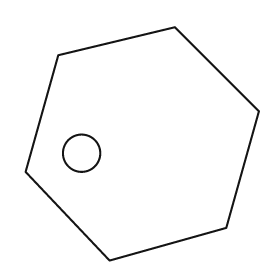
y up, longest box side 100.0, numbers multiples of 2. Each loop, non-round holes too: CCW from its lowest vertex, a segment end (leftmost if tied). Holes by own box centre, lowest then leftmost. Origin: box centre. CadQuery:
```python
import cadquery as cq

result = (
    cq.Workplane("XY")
    .moveTo(-14.0, -50.0)
    .lineTo(36.0, -36.0)
    .lineTo(50.0, 14.0)
    .lineTo(14.0, 50.0)
    .lineTo(-36.0, 38.0)
    .lineTo(-50.0, -12.0)
    .close()
    .moveTo(-26.0, -4.0)
    .circle(8.0)
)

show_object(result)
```